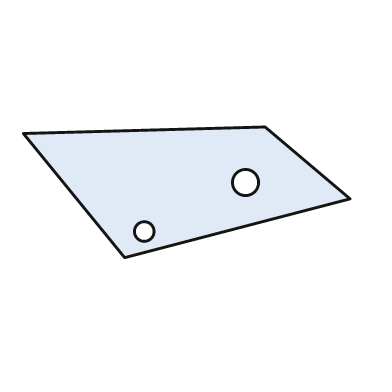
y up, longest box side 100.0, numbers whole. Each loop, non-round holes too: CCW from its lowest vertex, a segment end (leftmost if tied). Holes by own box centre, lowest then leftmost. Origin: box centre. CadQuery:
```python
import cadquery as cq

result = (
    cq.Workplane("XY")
    .moveTo(-19.0, -20.0)
    .lineTo(50.0, -2.0)
    .lineTo(24.0, 20.0)
    .lineTo(-50.0, 18.0)
    .close()
    .moveTo(-13.0, -12.0)
    .circle(3.0)
    .moveTo(18.0, 3.0)
    .circle(4.0)
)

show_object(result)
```